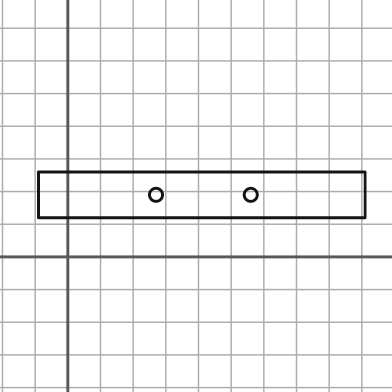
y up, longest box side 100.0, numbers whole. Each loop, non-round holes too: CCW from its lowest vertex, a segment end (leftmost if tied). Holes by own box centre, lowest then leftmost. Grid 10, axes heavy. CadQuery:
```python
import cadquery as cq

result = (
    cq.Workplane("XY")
    .moveTo(-9.0, 12.0)
    .lineTo(91.0, 12.0)
    .lineTo(91.0, 26.0)
    .lineTo(-9.0, 26.0)
    .close()
    .moveTo(27.0, 19.0)
    .circle(2.0)
    .moveTo(56.0, 19.0)
    .circle(2.0)
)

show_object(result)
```